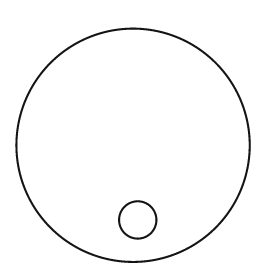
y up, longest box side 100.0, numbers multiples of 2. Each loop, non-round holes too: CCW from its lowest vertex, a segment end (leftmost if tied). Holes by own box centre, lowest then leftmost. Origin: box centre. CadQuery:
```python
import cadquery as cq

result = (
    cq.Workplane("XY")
    .moveTo(0.0, 0.0)
    .circle(50.0)
    .moveTo(2.0, -32.0)
    .circle(8.0)
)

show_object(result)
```